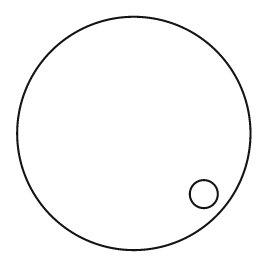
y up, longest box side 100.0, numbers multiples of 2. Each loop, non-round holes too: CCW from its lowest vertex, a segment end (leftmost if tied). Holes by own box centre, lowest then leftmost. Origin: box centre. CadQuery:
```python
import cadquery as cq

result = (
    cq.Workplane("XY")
    .moveTo(0.0, 0.0)
    .circle(50.0)
    .moveTo(30.0, -26.0)
    .circle(6.0)
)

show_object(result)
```